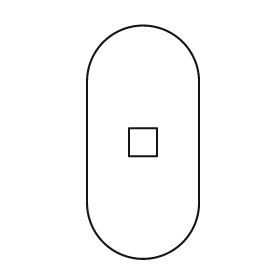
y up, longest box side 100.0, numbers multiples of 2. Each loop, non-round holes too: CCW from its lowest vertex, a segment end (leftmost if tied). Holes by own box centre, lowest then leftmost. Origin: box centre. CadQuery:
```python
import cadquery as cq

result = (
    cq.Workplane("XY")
    .moveTo(-24.0, -26.0)
    .threePointArc((0.0, -50.0), (24.0, -26.0))
    .lineTo(24.0, 26.0)
    .threePointArc((0.0, 50.0), (-24.0, 26.0))
    .close()
    .moveTo(-6.0, -6.0)
    .lineTo(6.0, -6.0)
    .lineTo(6.0, 6.0)
    .lineTo(-6.0, 6.0)
    .close()
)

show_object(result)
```